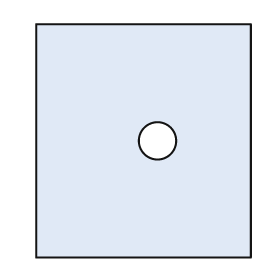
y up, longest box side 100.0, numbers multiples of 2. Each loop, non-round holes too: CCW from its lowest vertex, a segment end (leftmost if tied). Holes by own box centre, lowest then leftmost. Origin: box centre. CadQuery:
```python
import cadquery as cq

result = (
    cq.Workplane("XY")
    .moveTo(-46.0, -50.0)
    .lineTo(46.0, -50.0)
    .lineTo(46.0, 50.0)
    .lineTo(-46.0, 50.0)
    .close()
    .moveTo(6.0, 0.0)
    .circle(8.0)
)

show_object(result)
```